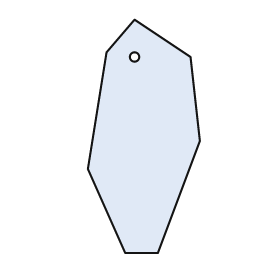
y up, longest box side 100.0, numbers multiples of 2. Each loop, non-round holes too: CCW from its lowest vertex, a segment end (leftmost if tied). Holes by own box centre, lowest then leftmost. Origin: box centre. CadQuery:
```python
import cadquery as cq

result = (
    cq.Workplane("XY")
    .moveTo(-8.0, -50.0)
    .lineTo(6.0, -50.0)
    .lineTo(24.0, -2.0)
    .lineTo(20.0, 34.0)
    .lineTo(-4.0, 50.0)
    .lineTo(-16.0, 36.0)
    .lineTo(-24.0, -14.0)
    .close()
    .moveTo(-4.0, 34.0)
    .circle(2.0)
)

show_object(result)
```